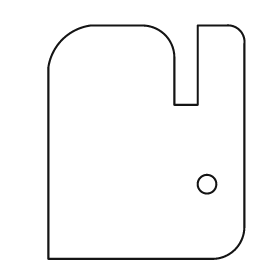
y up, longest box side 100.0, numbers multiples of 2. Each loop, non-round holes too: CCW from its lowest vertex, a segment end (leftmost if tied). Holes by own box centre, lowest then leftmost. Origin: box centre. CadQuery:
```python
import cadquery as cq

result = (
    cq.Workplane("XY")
    .moveTo(-42.0, -50.0)
    .lineTo(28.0, -50.0)
    .threePointArc((38.0, -46.0), (42.0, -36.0))
    .lineTo(42.0, 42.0)
    .threePointArc((40.0, 48.0), (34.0, 50.0))
    .lineTo(22.0, 50.0)
    .lineTo(22.0, 16.0)
    .lineTo(12.0, 16.0)
    .lineTo(12.0, 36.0)
    .threePointArc((8.0, 46.0), (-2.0, 50.0))
    .lineTo(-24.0, 50.0)
    .threePointArc((-36.0, 44.0), (-42.0, 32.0))
    .close()
    .moveTo(26.0, -18.0)
    .circle(4.0)
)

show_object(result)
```